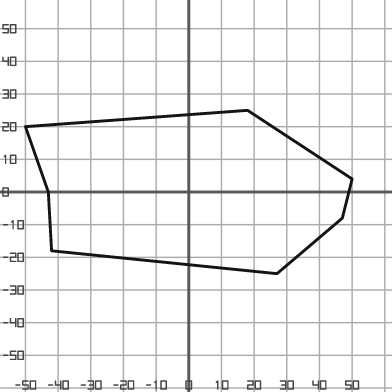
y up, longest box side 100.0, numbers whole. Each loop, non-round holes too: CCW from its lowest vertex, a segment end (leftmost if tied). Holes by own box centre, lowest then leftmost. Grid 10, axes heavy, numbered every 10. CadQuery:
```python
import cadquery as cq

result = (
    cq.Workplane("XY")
    .moveTo(27.0, -25.0)
    .lineTo(47.0, -8.0)
    .lineTo(50.0, 4.0)
    .lineTo(18.0, 25.0)
    .lineTo(-50.0, 20.0)
    .lineTo(-43.0, 0.0)
    .lineTo(-42.0, -18.0)
    .close()
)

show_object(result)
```